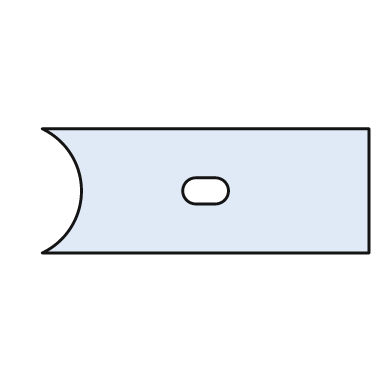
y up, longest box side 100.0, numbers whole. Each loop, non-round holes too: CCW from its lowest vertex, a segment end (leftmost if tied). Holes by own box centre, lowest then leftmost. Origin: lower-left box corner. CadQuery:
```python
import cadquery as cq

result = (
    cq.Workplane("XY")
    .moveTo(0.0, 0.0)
    .lineTo(100.0, 0.0)
    .lineTo(100.0, 38.0)
    .lineTo(0.0, 38.0)
    .threePointArc((12.0, 19.0), (0.0, 0.0))
    .close()
    .moveTo(47.0, 15.0)
    .lineTo(53.0, 15.0)
    .threePointArc((57.0, 19.0), (53.0, 23.0))
    .lineTo(47.0, 23.0)
    .threePointArc((43.0, 19.0), (47.0, 15.0))
    .close()
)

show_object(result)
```